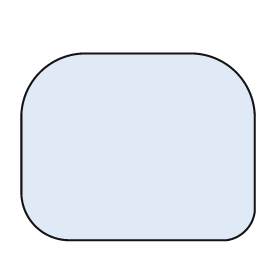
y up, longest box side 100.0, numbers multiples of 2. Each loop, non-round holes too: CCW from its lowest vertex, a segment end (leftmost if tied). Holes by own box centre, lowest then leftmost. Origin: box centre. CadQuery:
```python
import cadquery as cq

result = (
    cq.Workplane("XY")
    .moveTo(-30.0, -40.0)
    .lineTo(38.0, -40.0)
    .threePointArc((46.0, -36.0), (50.0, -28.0))
    .lineTo(50.0, 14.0)
    .threePointArc((42.0, 32.0), (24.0, 40.0))
    .lineTo(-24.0, 40.0)
    .threePointArc((-42.0, 32.0), (-50.0, 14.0))
    .lineTo(-50.0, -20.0)
    .threePointArc((-44.0, -34.0), (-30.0, -40.0))
    .close()
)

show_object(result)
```